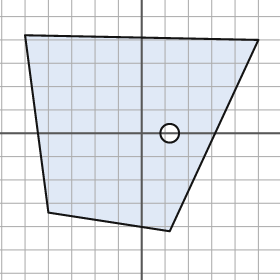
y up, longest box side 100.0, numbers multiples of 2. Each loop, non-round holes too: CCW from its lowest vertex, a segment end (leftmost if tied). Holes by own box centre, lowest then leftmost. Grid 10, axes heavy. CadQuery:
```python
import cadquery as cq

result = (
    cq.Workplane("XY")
    .moveTo(12.0, -42.0)
    .lineTo(50.0, 40.0)
    .lineTo(-50.0, 42.0)
    .lineTo(-40.0, -34.0)
    .close()
    .moveTo(12.0, 0.0)
    .circle(4.0)
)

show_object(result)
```